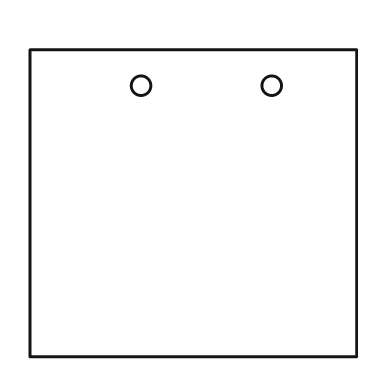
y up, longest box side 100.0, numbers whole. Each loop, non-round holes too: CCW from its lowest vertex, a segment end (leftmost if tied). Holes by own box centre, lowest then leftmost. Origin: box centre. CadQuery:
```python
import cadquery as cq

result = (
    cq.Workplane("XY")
    .moveTo(-50.0, -47.0)
    .lineTo(50.0, -47.0)
    .lineTo(50.0, 47.0)
    .lineTo(-50.0, 47.0)
    .close()
    .moveTo(-16.0, 36.0)
    .circle(3.0)
    .moveTo(24.0, 36.0)
    .circle(3.0)
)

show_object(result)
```